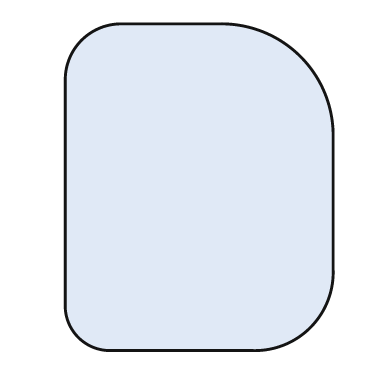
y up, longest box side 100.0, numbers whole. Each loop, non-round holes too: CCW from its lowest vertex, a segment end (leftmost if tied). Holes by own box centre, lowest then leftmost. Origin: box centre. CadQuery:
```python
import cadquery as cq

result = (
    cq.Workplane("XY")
    .moveTo(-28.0, -50.0)
    .lineTo(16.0, -50.0)
    .threePointArc((34.0, -43.0), (41.0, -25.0))
    .lineTo(41.0, 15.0)
    .threePointArc((31.0, 40.0), (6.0, 50.0))
    .lineTo(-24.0, 50.0)
    .threePointArc((-36.0, 45.0), (-41.0, 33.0))
    .lineTo(-41.0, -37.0)
    .threePointArc((-37.0, -46.0), (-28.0, -50.0))
    .close()
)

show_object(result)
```